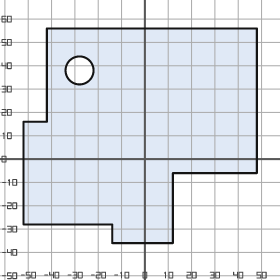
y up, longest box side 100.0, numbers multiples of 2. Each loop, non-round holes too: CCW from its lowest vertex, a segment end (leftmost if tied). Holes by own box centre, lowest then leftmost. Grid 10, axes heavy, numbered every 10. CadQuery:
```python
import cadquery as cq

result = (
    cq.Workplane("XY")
    .moveTo(-14.0, -36.0)
    .lineTo(12.0, -36.0)
    .lineTo(12.0, -6.0)
    .lineTo(48.0, -6.0)
    .lineTo(48.0, 56.0)
    .lineTo(-42.0, 56.0)
    .lineTo(-42.0, 16.0)
    .lineTo(-52.0, 16.0)
    .lineTo(-52.0, -28.0)
    .lineTo(-14.0, -28.0)
    .close()
    .moveTo(-28.0, 38.0)
    .circle(6.0)
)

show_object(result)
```